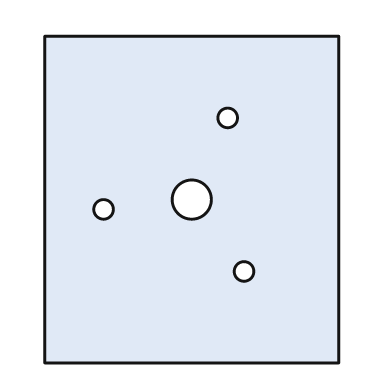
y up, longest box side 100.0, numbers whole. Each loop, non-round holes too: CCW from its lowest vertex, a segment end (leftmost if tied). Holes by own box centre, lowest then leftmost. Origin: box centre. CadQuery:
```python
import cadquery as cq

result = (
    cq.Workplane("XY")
    .moveTo(-45.0, -50.0)
    .lineTo(45.0, -50.0)
    .lineTo(45.0, 50.0)
    .lineTo(-45.0, 50.0)
    .close()
    .moveTo(16.0, -22.0)
    .circle(3.0)
    .moveTo(-27.0, -3.0)
    .circle(3.0)
    .moveTo(0.0, 0.0)
    .circle(6.0)
    .moveTo(11.0, 25.0)
    .circle(3.0)
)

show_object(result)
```